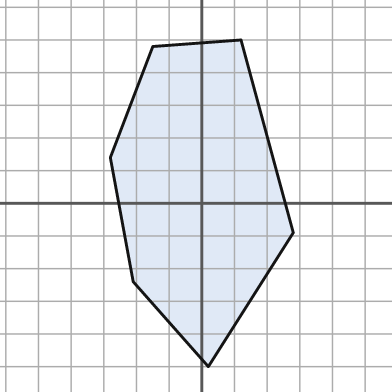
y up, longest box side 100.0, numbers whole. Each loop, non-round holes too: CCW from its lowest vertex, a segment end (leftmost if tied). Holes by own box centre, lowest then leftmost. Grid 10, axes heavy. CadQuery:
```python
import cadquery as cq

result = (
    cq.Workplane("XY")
    .moveTo(2.0, -50.0)
    .lineTo(28.0, -9.0)
    .lineTo(12.0, 50.0)
    .lineTo(-15.0, 48.0)
    .lineTo(-28.0, 14.0)
    .lineTo(-21.0, -24.0)
    .close()
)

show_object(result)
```